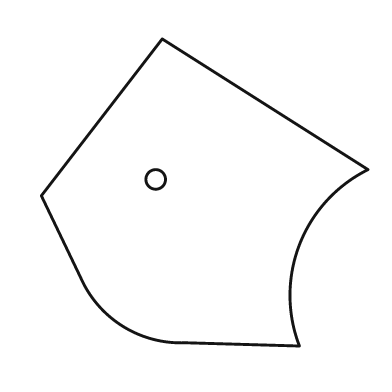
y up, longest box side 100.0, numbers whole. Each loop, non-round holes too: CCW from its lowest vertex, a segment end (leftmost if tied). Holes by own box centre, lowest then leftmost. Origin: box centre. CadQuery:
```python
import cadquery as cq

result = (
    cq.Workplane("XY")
    .moveTo(29.0, -47.0)
    .threePointArc((29.0, -16.0), (50.0, 7.0))
    .lineTo(-13.0, 47.0)
    .lineTo(-50.0, -1.0)
    .lineTo(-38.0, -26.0)
    .threePointArc((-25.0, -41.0), (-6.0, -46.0))
    .close()
    .moveTo(-15.0, 4.0)
    .circle(3.0)
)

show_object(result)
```